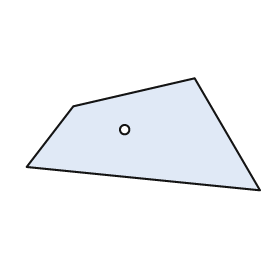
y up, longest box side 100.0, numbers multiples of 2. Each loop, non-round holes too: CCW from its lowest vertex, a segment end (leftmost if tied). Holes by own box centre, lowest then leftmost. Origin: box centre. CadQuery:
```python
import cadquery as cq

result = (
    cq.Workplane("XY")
    .moveTo(50.0, -24.0)
    .lineTo(22.0, 24.0)
    .lineTo(-30.0, 12.0)
    .lineTo(-50.0, -14.0)
    .close()
    .moveTo(-8.0, 2.0)
    .circle(2.0)
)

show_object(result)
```